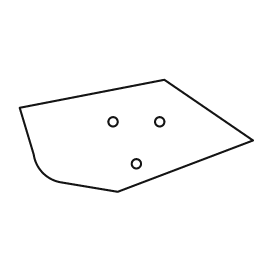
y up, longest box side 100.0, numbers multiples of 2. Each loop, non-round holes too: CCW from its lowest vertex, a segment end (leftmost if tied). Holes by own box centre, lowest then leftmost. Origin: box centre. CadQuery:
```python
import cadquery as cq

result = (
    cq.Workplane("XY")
    .moveTo(-8.0, -24.0)
    .lineTo(50.0, -2.0)
    .lineTo(12.0, 24.0)
    .lineTo(-50.0, 12.0)
    .lineTo(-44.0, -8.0)
    .threePointArc((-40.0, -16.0), (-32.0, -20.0))
    .close()
    .moveTo(0.0, -12.0)
    .circle(2.0)
    .moveTo(-10.0, 6.0)
    .circle(2.0)
    .moveTo(10.0, 6.0)
    .circle(2.0)
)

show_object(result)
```